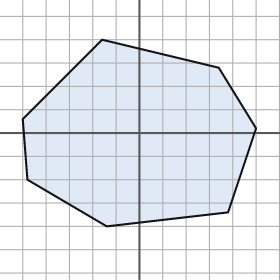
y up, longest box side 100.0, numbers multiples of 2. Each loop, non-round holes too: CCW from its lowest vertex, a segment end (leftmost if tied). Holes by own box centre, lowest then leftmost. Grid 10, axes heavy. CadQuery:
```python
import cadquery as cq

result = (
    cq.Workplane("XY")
    .moveTo(-14.0, -40.0)
    .lineTo(38.0, -34.0)
    .lineTo(50.0, 2.0)
    .lineTo(34.0, 28.0)
    .lineTo(-16.0, 40.0)
    .lineTo(-50.0, 6.0)
    .lineTo(-48.0, -20.0)
    .close()
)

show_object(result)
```